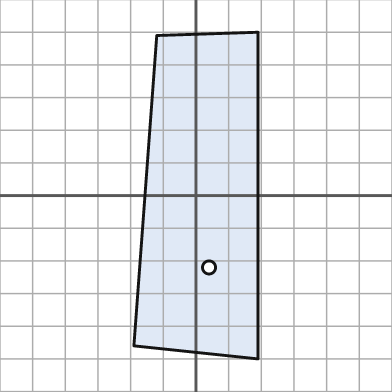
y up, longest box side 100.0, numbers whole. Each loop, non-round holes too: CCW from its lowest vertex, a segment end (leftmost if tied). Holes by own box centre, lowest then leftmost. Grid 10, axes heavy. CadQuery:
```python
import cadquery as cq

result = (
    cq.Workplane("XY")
    .moveTo(19.0, -50.0)
    .lineTo(19.0, 50.0)
    .lineTo(-12.0, 49.0)
    .lineTo(-19.0, -46.0)
    .close()
    .moveTo(4.0, -22.0)
    .circle(2.0)
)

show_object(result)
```